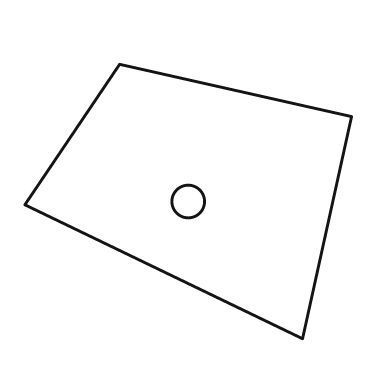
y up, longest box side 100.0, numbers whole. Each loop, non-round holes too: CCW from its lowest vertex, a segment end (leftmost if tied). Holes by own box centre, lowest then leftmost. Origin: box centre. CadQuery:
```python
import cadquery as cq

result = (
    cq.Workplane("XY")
    .moveTo(35.0, -42.0)
    .lineTo(50.0, 26.0)
    .lineTo(-21.0, 42.0)
    .lineTo(-50.0, -1.0)
    .close()
    .moveTo(0.0, 0.0)
    .circle(5.0)
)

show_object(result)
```